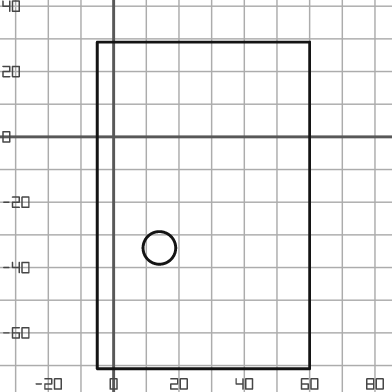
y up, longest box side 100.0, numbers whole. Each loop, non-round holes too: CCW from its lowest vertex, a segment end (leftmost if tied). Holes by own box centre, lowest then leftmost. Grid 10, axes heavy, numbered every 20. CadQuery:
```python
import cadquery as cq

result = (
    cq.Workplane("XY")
    .moveTo(-5.0, -71.0)
    .lineTo(60.0, -71.0)
    .lineTo(60.0, 29.0)
    .lineTo(-5.0, 29.0)
    .close()
    .moveTo(14.0, -34.0)
    .circle(5.0)
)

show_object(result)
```